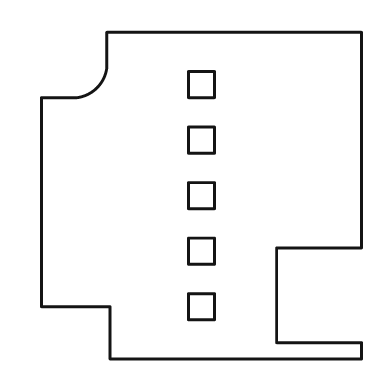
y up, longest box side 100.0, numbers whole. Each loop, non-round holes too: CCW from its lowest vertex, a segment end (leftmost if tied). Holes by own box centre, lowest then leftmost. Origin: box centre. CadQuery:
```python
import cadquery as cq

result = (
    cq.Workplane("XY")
    .moveTo(-28.0, -50.0)
    .lineTo(49.0, -50.0)
    .lineTo(49.0, -45.0)
    .lineTo(23.0, -45.0)
    .lineTo(23.0, -16.0)
    .lineTo(49.0, -16.0)
    .lineTo(49.0, 50.0)
    .lineTo(-29.0, 50.0)
    .lineTo(-29.0, 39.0)
    .threePointArc((-32.0, 33.0), (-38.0, 30.0))
    .lineTo(-49.0, 30.0)
    .lineTo(-49.0, -34.0)
    .lineTo(-28.0, -34.0)
    .close()
    .moveTo(-4.0, -38.0)
    .lineTo(4.0, -38.0)
    .lineTo(4.0, -30.0)
    .lineTo(-4.0, -30.0)
    .close()
    .moveTo(-4.0, -21.0)
    .lineTo(4.0, -21.0)
    .lineTo(4.0, -13.0)
    .lineTo(-4.0, -13.0)
    .close()
    .moveTo(-4.0, -4.0)
    .lineTo(4.0, -4.0)
    .lineTo(4.0, 4.0)
    .lineTo(-4.0, 4.0)
    .close()
    .moveTo(-4.0, 13.0)
    .lineTo(4.0, 13.0)
    .lineTo(4.0, 21.0)
    .lineTo(-4.0, 21.0)
    .close()
    .moveTo(-4.0, 30.0)
    .lineTo(4.0, 30.0)
    .lineTo(4.0, 38.0)
    .lineTo(-4.0, 38.0)
    .close()
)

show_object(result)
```